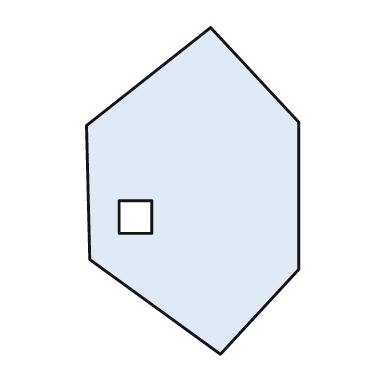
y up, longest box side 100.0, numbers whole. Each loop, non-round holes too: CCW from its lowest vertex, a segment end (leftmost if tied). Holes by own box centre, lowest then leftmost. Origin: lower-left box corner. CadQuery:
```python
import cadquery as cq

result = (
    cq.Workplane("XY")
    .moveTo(41.0, 0.0)
    .lineTo(65.0, 26.0)
    .lineTo(65.0, 71.0)
    .lineTo(38.0, 100.0)
    .lineTo(0.0, 70.0)
    .lineTo(1.0, 29.0)
    .close()
    .moveTo(10.0, 37.0)
    .lineTo(20.0, 37.0)
    .lineTo(20.0, 47.0)
    .lineTo(10.0, 47.0)
    .close()
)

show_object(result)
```